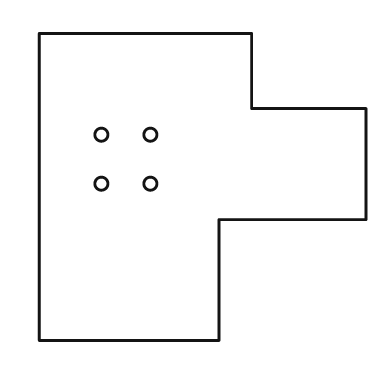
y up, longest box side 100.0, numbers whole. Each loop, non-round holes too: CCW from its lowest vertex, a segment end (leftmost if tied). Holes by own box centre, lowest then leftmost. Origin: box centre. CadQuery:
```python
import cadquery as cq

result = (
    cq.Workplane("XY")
    .moveTo(-50.0, -47.0)
    .lineTo(5.0, -47.0)
    .lineTo(5.0, -10.0)
    .lineTo(50.0, -10.0)
    .lineTo(50.0, 24.0)
    .lineTo(15.0, 24.0)
    .lineTo(15.0, 47.0)
    .lineTo(-50.0, 47.0)
    .close()
    .moveTo(-31.0, 1.0)
    .circle(2.0)
    .moveTo(-16.0, 1.0)
    .circle(2.0)
    .moveTo(-31.0, 16.0)
    .circle(2.0)
    .moveTo(-16.0, 16.0)
    .circle(2.0)
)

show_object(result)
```